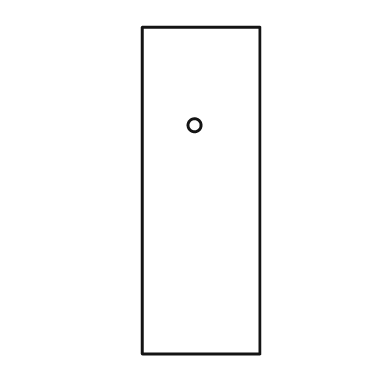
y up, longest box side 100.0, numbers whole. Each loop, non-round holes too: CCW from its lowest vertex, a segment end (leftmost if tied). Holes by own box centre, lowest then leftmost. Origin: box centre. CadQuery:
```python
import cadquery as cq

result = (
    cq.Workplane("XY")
    .moveTo(-18.0, -50.0)
    .lineTo(18.0, -50.0)
    .lineTo(18.0, 50.0)
    .lineTo(-18.0, 50.0)
    .close()
    .moveTo(-2.0, 20.0)
    .circle(2.0)
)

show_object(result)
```